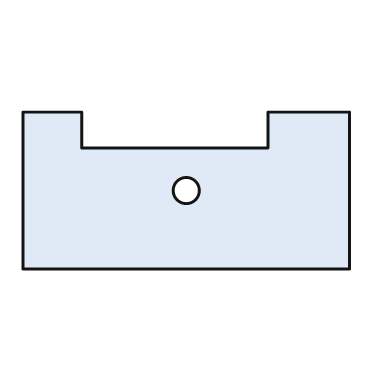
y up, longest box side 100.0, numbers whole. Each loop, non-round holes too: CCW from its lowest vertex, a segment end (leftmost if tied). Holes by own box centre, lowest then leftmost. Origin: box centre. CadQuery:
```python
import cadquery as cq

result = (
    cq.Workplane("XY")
    .moveTo(-50.0, -24.0)
    .lineTo(50.0, -24.0)
    .lineTo(50.0, 24.0)
    .lineTo(25.0, 24.0)
    .lineTo(25.0, 13.0)
    .lineTo(-32.0, 13.0)
    .lineTo(-32.0, 24.0)
    .lineTo(-50.0, 24.0)
    .close()
    .moveTo(0.0, 0.0)
    .circle(4.0)
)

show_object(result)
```